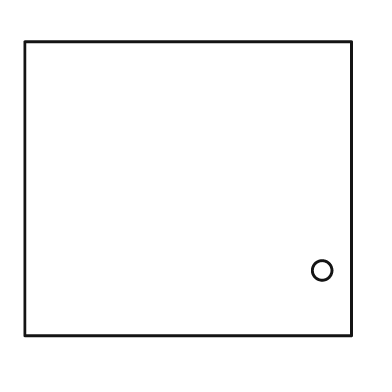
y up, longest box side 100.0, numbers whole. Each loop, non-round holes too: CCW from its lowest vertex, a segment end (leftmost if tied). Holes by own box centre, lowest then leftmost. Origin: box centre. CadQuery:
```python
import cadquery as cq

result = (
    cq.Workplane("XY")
    .moveTo(-50.0, -45.0)
    .lineTo(50.0, -45.0)
    .lineTo(50.0, 45.0)
    .lineTo(-50.0, 45.0)
    .close()
    .moveTo(41.0, -25.0)
    .circle(3.0)
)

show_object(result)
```